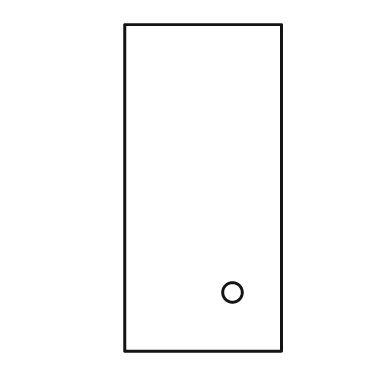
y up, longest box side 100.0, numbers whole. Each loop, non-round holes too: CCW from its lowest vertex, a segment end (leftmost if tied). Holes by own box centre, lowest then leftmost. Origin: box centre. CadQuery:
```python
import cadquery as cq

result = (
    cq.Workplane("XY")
    .moveTo(-24.0, -50.0)
    .lineTo(24.0, -50.0)
    .lineTo(24.0, 50.0)
    .lineTo(-24.0, 50.0)
    .close()
    .moveTo(9.0, -32.0)
    .circle(3.0)
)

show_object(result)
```